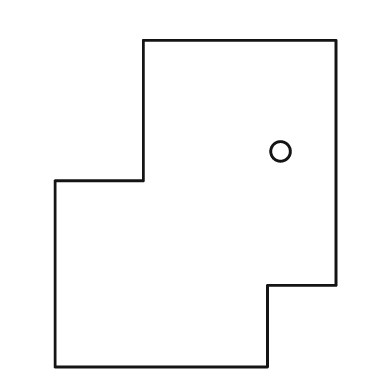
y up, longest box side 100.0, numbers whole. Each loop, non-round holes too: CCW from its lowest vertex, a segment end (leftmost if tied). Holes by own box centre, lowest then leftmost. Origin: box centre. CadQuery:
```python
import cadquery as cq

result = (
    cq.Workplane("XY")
    .moveTo(-43.0, -50.0)
    .lineTo(22.0, -50.0)
    .lineTo(22.0, -25.0)
    .lineTo(43.0, -25.0)
    .lineTo(43.0, 50.0)
    .lineTo(-16.0, 50.0)
    .lineTo(-16.0, 7.0)
    .lineTo(-43.0, 7.0)
    .close()
    .moveTo(26.0, 16.0)
    .circle(3.0)
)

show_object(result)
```